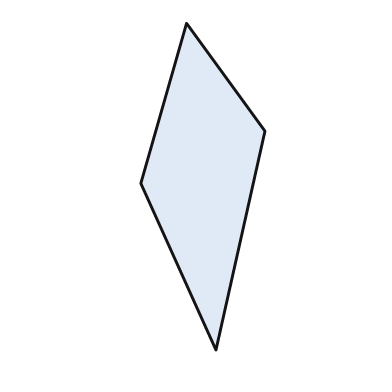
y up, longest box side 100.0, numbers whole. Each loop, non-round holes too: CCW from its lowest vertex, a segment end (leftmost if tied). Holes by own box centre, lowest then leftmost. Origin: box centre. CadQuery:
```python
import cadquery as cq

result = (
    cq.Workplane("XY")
    .moveTo(4.0, -50.0)
    .lineTo(19.0, 17.0)
    .lineTo(-5.0, 50.0)
    .lineTo(-19.0, 1.0)
    .close()
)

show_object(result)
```